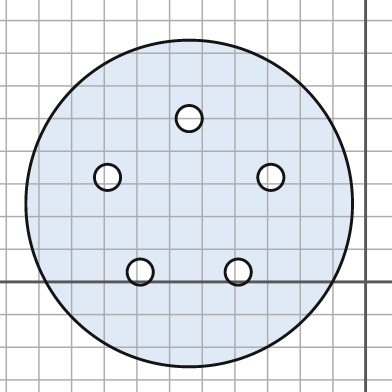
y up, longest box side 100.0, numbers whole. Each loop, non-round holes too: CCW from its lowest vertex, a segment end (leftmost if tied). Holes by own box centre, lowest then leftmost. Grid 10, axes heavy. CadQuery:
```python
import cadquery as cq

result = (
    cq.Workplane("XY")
    .moveTo(-54.0, 24.0)
    .circle(50.0)
    .moveTo(-69.0, 3.0)
    .circle(4.0)
    .moveTo(-39.0, 3.0)
    .circle(4.0)
    .moveTo(-79.0, 32.0)
    .circle(4.0)
    .moveTo(-29.0, 32.0)
    .circle(4.0)
    .moveTo(-54.0, 50.0)
    .circle(4.0)
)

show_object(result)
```